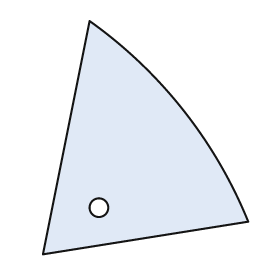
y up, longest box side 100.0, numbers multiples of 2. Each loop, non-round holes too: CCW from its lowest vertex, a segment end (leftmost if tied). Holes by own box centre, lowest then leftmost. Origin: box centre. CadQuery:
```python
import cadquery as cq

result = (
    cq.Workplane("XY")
    .moveTo(-44.0, -50.0)
    .lineTo(44.0, -36.0)
    .threePointArc((16.0, 12.0), (-24.0, 50.0))
    .close()
    .moveTo(-20.0, -30.0)
    .circle(4.0)
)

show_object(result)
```